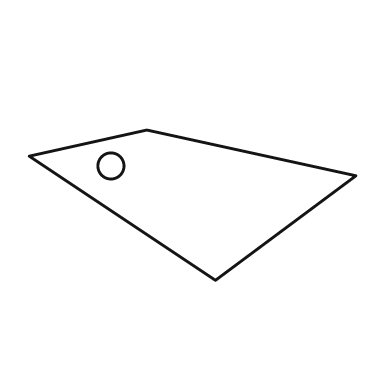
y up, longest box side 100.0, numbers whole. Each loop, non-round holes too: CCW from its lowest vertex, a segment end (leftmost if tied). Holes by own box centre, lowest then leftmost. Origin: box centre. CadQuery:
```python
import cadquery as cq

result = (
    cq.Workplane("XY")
    .moveTo(7.0, -23.0)
    .lineTo(50.0, 9.0)
    .lineTo(-14.0, 23.0)
    .lineTo(-50.0, 15.0)
    .close()
    .moveTo(-25.0, 12.0)
    .circle(4.0)
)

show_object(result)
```